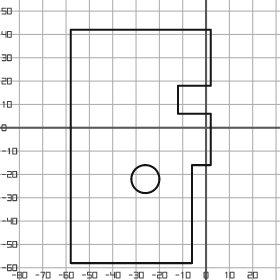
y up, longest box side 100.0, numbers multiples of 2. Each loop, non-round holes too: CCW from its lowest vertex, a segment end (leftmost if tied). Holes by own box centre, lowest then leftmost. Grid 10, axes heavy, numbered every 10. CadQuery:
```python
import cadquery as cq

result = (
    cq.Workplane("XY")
    .moveTo(-58.0, -58.0)
    .lineTo(-6.0, -58.0)
    .lineTo(-6.0, -16.0)
    .lineTo(2.0, -16.0)
    .lineTo(2.0, 6.0)
    .lineTo(-12.0, 6.0)
    .lineTo(-12.0, 18.0)
    .lineTo(2.0, 18.0)
    .lineTo(2.0, 42.0)
    .lineTo(-58.0, 42.0)
    .close()
    .moveTo(-26.0, -22.0)
    .circle(6.0)
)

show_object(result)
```